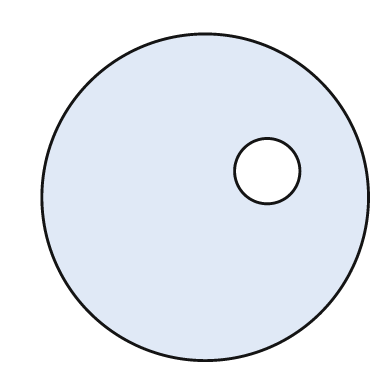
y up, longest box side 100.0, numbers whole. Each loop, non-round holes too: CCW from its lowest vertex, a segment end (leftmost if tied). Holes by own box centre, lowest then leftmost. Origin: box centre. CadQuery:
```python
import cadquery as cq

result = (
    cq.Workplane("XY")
    .moveTo(0.0, 0.0)
    .circle(50.0)
    .moveTo(19.0, 8.0)
    .circle(10.0)
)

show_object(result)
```